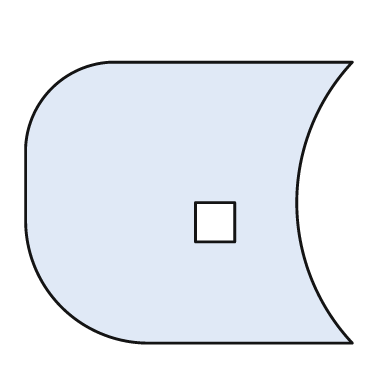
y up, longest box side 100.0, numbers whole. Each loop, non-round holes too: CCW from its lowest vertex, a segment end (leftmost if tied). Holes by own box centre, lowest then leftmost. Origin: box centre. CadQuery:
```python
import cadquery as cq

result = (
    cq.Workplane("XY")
    .moveTo(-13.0, -43.0)
    .lineTo(50.0, -43.0)
    .threePointArc((33.0, 0.0), (50.0, 43.0))
    .lineTo(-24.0, 43.0)
    .threePointArc((-42.0, 35.0), (-50.0, 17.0))
    .lineTo(-50.0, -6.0)
    .threePointArc((-39.0, -32.0), (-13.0, -43.0))
    .close()
    .moveTo(2.0, -12.0)
    .lineTo(14.0, -12.0)
    .lineTo(14.0, 0.0)
    .lineTo(2.0, 0.0)
    .close()
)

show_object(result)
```